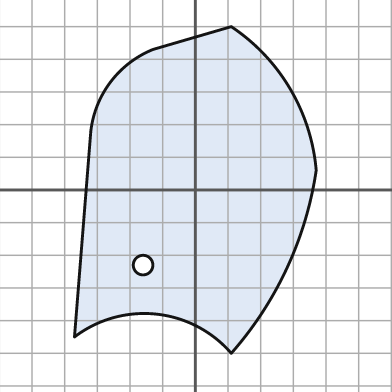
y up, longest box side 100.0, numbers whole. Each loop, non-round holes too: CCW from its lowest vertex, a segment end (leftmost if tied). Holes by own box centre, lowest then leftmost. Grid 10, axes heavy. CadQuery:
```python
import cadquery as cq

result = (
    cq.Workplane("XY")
    .moveTo(11.0, -50.0)
    .threePointArc((28.0, -24.0), (37.0, 6.0))
    .threePointArc((29.0, 31.0), (11.0, 50.0))
    .lineTo(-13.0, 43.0)
    .threePointArc((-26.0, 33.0), (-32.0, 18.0))
    .lineTo(-37.0, -45.0)
    .threePointArc((-12.0, -38.0), (11.0, -50.0))
    .close()
    .moveTo(-16.0, -23.0)
    .circle(3.0)
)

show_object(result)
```